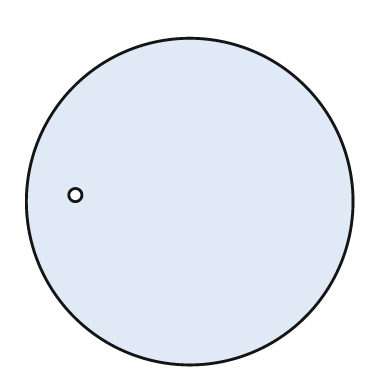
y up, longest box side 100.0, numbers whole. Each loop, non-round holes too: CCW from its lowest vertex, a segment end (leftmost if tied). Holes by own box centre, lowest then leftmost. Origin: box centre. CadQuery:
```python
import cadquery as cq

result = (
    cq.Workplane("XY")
    .moveTo(0.0, 0.0)
    .circle(50.0)
    .moveTo(-35.0, 2.0)
    .circle(2.0)
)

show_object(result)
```